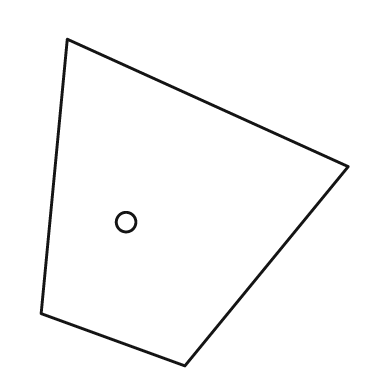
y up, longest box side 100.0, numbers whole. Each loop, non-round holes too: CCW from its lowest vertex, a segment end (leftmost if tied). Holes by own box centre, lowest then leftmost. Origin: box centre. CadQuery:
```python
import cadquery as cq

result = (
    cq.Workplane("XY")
    .moveTo(-3.0, -50.0)
    .lineTo(47.0, 11.0)
    .lineTo(-39.0, 50.0)
    .lineTo(-47.0, -34.0)
    .close()
    .moveTo(-21.0, -6.0)
    .circle(3.0)
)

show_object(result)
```